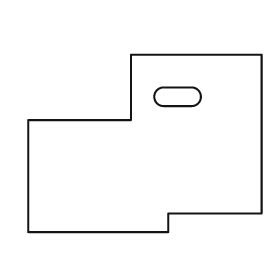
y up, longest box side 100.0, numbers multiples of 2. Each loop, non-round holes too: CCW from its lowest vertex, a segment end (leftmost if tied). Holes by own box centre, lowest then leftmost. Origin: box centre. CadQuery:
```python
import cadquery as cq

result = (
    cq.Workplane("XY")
    .moveTo(-50.0, -38.0)
    .lineTo(10.0, -38.0)
    .lineTo(10.0, -30.0)
    .lineTo(50.0, -30.0)
    .lineTo(50.0, 38.0)
    .lineTo(-6.0, 38.0)
    .lineTo(-6.0, 10.0)
    .lineTo(-50.0, 10.0)
    .close()
    .moveTo(8.0, 16.0)
    .lineTo(20.0, 16.0)
    .threePointArc((24.0, 20.0), (20.0, 24.0))
    .lineTo(8.0, 24.0)
    .threePointArc((4.0, 20.0), (8.0, 16.0))
    .close()
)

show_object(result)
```